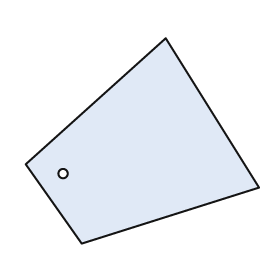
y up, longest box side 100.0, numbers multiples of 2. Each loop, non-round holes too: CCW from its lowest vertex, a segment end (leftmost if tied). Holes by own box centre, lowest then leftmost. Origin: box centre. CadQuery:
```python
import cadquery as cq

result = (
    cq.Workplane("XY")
    .moveTo(-26.0, -44.0)
    .lineTo(50.0, -20.0)
    .lineTo(10.0, 44.0)
    .lineTo(-50.0, -10.0)
    .close()
    .moveTo(-34.0, -14.0)
    .circle(2.0)
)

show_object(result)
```